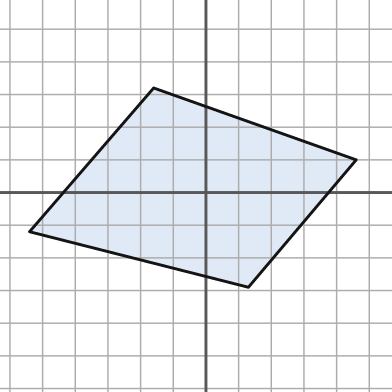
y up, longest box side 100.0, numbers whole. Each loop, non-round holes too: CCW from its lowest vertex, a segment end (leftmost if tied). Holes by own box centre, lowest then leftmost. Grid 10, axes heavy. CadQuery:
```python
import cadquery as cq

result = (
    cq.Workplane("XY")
    .moveTo(13.0, -29.0)
    .lineTo(46.0, 10.0)
    .lineTo(-16.0, 32.0)
    .lineTo(-54.0, -12.0)
    .close()
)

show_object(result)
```